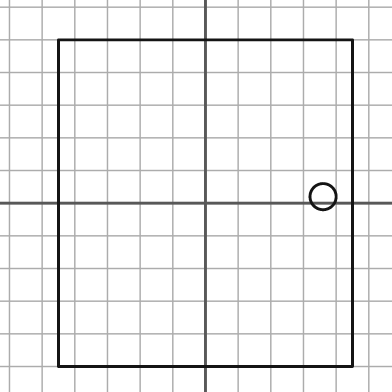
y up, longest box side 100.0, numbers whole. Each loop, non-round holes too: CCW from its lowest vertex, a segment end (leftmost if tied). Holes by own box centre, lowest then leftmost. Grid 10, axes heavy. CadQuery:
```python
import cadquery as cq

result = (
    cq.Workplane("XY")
    .moveTo(-45.0, -50.0)
    .lineTo(45.0, -50.0)
    .lineTo(45.0, 50.0)
    .lineTo(-45.0, 50.0)
    .close()
    .moveTo(36.0, 2.0)
    .circle(4.0)
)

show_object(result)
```